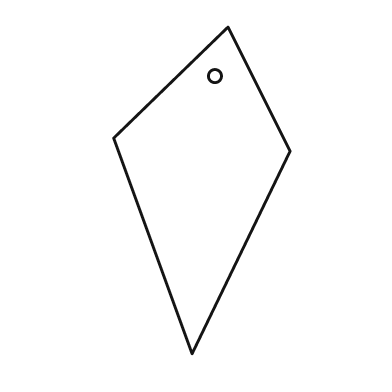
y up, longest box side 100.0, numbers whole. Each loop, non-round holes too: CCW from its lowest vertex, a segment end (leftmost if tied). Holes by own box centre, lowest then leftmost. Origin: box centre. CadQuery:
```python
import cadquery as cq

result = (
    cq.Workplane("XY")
    .moveTo(-3.0, -50.0)
    .lineTo(27.0, 12.0)
    .lineTo(8.0, 50.0)
    .lineTo(-27.0, 16.0)
    .close()
    .moveTo(4.0, 35.0)
    .circle(2.0)
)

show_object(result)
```